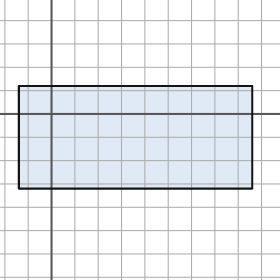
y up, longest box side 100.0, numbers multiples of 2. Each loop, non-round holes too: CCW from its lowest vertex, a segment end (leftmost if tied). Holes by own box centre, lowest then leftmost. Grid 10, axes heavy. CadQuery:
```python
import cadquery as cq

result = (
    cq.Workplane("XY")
    .moveTo(-14.0, -32.0)
    .lineTo(86.0, -32.0)
    .lineTo(86.0, 12.0)
    .lineTo(-14.0, 12.0)
    .close()
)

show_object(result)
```